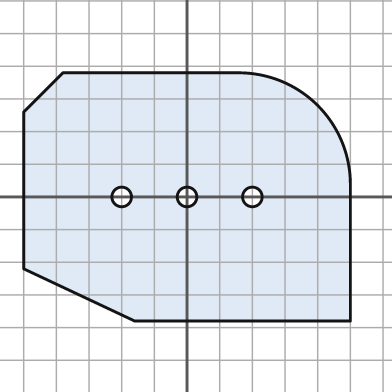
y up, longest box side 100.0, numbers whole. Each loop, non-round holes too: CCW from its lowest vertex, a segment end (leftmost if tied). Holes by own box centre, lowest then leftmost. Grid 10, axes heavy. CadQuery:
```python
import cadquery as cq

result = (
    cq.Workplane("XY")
    .moveTo(-16.0, -38.0)
    .lineTo(50.0, -38.0)
    .lineTo(50.0, 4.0)
    .threePointArc((40.0, 28.0), (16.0, 38.0))
    .lineTo(-38.0, 38.0)
    .lineTo(-50.0, 26.0)
    .lineTo(-50.0, -22.0)
    .close()
    .moveTo(-20.0, 0.0)
    .circle(3.0)
    .moveTo(0.0, 0.0)
    .circle(3.0)
    .moveTo(20.0, 0.0)
    .circle(3.0)
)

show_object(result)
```